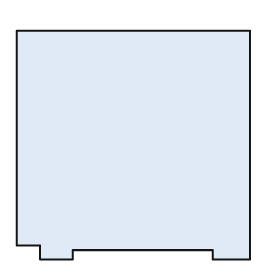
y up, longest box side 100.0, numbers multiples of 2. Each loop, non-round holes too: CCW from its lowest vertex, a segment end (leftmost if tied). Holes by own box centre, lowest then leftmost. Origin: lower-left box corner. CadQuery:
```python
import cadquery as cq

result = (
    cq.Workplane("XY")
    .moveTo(10.0, 0.0)
    .lineTo(24.0, 0.0)
    .lineTo(24.0, 4.0)
    .lineTo(84.0, 4.0)
    .lineTo(84.0, 0.0)
    .lineTo(100.0, 0.0)
    .lineTo(100.0, 98.0)
    .lineTo(0.0, 98.0)
    .lineTo(0.0, 6.0)
    .lineTo(10.0, 6.0)
    .close()
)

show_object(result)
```